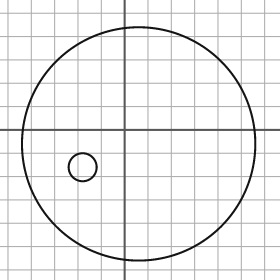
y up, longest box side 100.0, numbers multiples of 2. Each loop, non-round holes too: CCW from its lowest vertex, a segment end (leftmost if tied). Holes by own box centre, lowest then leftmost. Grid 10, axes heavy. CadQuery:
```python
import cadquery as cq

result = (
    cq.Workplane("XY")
    .moveTo(6.0, -6.0)
    .circle(50.0)
    .moveTo(-18.0, -16.0)
    .circle(6.0)
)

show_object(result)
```